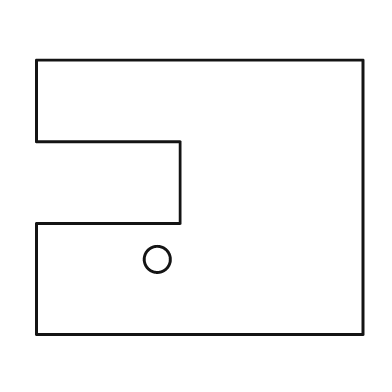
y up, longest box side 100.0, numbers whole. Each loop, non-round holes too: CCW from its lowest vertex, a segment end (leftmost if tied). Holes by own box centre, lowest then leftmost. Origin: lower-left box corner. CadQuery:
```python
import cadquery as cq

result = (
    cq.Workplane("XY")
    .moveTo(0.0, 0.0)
    .lineTo(100.0, 0.0)
    .lineTo(100.0, 84.0)
    .lineTo(0.0, 84.0)
    .lineTo(0.0, 59.0)
    .lineTo(44.0, 59.0)
    .lineTo(44.0, 34.0)
    .lineTo(0.0, 34.0)
    .close()
    .moveTo(37.0, 23.0)
    .circle(4.0)
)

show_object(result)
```